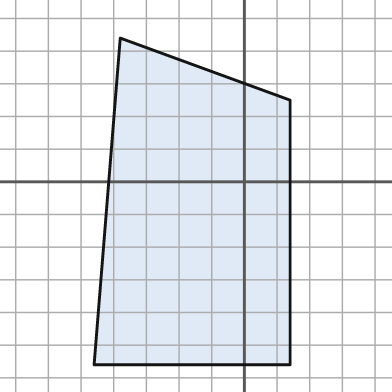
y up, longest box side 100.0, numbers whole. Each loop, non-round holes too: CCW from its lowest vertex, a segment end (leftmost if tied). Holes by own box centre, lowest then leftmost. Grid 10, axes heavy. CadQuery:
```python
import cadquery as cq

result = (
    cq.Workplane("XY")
    .moveTo(-46.0, -56.0)
    .lineTo(14.0, -56.0)
    .lineTo(14.0, 25.0)
    .lineTo(-38.0, 44.0)
    .close()
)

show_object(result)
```